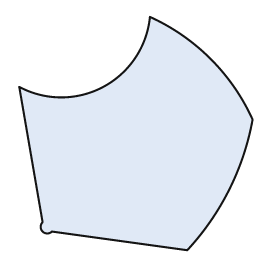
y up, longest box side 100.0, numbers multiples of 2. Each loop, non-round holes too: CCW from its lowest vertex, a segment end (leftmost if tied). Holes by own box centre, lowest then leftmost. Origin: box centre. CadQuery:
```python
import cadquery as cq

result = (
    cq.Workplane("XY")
    .moveTo(22.0, -50.0)
    .threePointArc((40.0, -24.0), (50.0, 6.0))
    .threePointArc((32.0, 32.0), (6.0, 50.0))
    .threePointArc((-14.0, 20.0), (-50.0, 20.0))
    .lineTo(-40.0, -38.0)
    .threePointArc((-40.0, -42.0), (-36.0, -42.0))
    .close()
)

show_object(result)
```